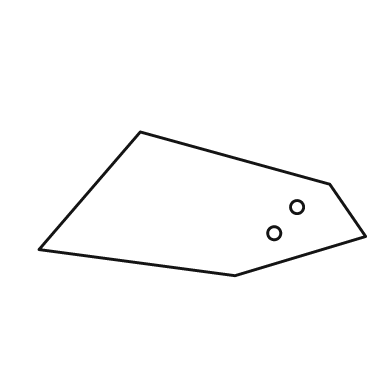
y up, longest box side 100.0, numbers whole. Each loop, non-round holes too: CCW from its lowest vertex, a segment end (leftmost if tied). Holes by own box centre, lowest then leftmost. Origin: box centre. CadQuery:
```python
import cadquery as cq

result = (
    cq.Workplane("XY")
    .moveTo(10.0, -22.0)
    .lineTo(50.0, -10.0)
    .lineTo(39.0, 6.0)
    .lineTo(-19.0, 22.0)
    .lineTo(-50.0, -14.0)
    .close()
    .moveTo(22.0, -9.0)
    .circle(2.0)
    .moveTo(29.0, -1.0)
    .circle(2.0)
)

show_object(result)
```